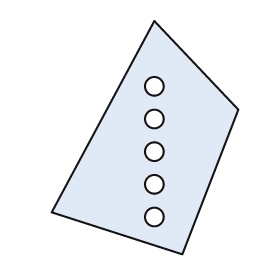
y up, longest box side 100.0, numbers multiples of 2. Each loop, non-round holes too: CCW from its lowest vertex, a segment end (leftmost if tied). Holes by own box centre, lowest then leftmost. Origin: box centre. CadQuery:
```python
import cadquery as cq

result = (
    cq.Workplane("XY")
    .moveTo(16.0, -50.0)
    .lineTo(40.0, 12.0)
    .lineTo(4.0, 50.0)
    .lineTo(-40.0, -32.0)
    .close()
    .moveTo(4.0, -34.0)
    .circle(4.0)
    .moveTo(4.0, -20.0)
    .circle(4.0)
    .moveTo(4.0, -6.0)
    .circle(4.0)
    .moveTo(4.0, 8.0)
    .circle(4.0)
    .moveTo(4.0, 22.0)
    .circle(4.0)
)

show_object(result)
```